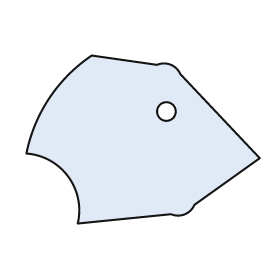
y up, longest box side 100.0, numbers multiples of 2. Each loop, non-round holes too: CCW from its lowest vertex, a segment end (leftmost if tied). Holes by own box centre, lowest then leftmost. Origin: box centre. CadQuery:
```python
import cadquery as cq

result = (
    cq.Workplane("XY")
    .moveTo(-28.0, -36.0)
    .lineTo(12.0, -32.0)
    .threePointArc((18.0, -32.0), (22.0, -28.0))
    .lineTo(50.0, -8.0)
    .lineTo(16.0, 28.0)
    .threePointArc((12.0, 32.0), (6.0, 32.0))
    .lineTo(-22.0, 36.0)
    .threePointArc((-40.0, 18.0), (-50.0, -6.0))
    .threePointArc((-32.0, -16.0), (-28.0, -36.0))
    .close()
    .moveTo(10.0, 12.0)
    .circle(4.0)
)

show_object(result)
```